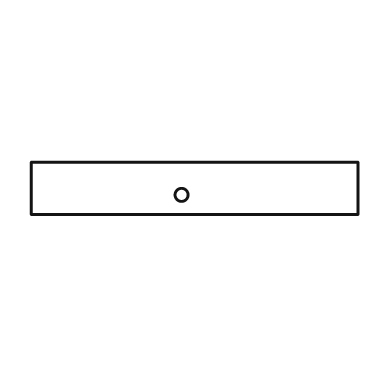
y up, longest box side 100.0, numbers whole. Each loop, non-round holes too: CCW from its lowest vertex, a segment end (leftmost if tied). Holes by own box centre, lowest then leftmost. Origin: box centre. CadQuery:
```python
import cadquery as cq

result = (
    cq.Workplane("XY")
    .moveTo(-50.0, -8.0)
    .lineTo(50.0, -8.0)
    .lineTo(50.0, 8.0)
    .lineTo(-50.0, 8.0)
    .close()
    .moveTo(-4.0, -2.0)
    .circle(2.0)
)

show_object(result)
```